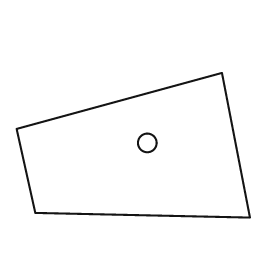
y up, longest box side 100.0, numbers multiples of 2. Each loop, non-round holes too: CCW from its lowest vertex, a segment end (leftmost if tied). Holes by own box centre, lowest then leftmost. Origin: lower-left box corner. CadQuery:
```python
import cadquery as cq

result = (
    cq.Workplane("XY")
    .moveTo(100.0, 0.0)
    .lineTo(88.0, 62.0)
    .lineTo(0.0, 38.0)
    .lineTo(8.0, 2.0)
    .close()
    .moveTo(56.0, 32.0)
    .circle(4.0)
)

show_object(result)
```